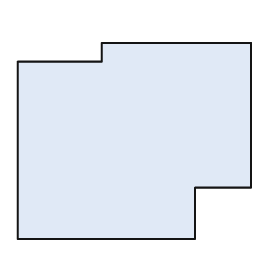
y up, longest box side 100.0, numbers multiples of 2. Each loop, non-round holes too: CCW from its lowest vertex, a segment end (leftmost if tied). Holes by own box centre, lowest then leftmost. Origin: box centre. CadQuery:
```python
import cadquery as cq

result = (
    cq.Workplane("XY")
    .moveTo(-50.0, -42.0)
    .lineTo(26.0, -42.0)
    .lineTo(26.0, -20.0)
    .lineTo(50.0, -20.0)
    .lineTo(50.0, 42.0)
    .lineTo(-14.0, 42.0)
    .lineTo(-14.0, 34.0)
    .lineTo(-50.0, 34.0)
    .close()
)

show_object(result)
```